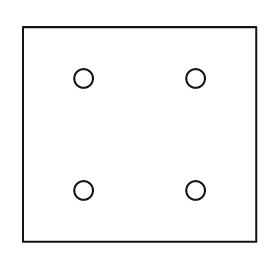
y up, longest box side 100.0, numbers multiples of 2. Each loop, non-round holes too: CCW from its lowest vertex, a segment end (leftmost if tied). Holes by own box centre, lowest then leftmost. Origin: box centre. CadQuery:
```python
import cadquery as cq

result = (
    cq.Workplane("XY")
    .moveTo(-50.0, -46.0)
    .lineTo(50.0, -46.0)
    .lineTo(50.0, 46.0)
    .lineTo(-50.0, 46.0)
    .close()
    .moveTo(-24.0, -24.0)
    .circle(4.0)
    .moveTo(24.0, -24.0)
    .circle(4.0)
    .moveTo(-24.0, 24.0)
    .circle(4.0)
    .moveTo(24.0, 24.0)
    .circle(4.0)
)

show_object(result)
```